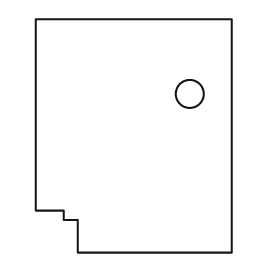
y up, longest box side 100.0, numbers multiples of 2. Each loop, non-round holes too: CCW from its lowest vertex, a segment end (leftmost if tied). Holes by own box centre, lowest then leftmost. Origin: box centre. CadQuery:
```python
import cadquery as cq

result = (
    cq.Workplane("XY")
    .moveTo(-24.0, -50.0)
    .lineTo(42.0, -50.0)
    .lineTo(42.0, 50.0)
    .lineTo(-42.0, 50.0)
    .lineTo(-42.0, -32.0)
    .lineTo(-30.0, -32.0)
    .lineTo(-30.0, -36.0)
    .lineTo(-24.0, -36.0)
    .close()
    .moveTo(24.0, 18.0)
    .circle(6.0)
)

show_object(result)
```